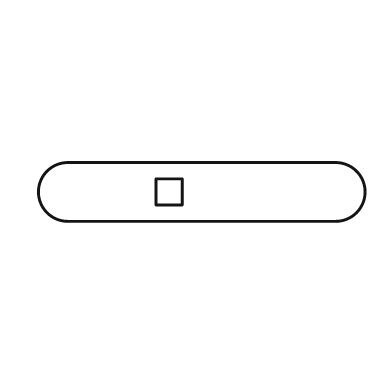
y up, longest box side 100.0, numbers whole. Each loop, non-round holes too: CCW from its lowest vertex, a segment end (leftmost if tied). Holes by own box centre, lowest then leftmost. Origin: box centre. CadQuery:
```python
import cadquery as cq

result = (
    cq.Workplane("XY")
    .moveTo(-41.0, -9.0)
    .lineTo(41.0, -9.0)
    .threePointArc((50.0, 0.0), (41.0, 9.0))
    .lineTo(-41.0, 9.0)
    .threePointArc((-50.0, 0.0), (-41.0, -9.0))
    .close()
    .moveTo(-14.0, -4.0)
    .lineTo(-6.0, -4.0)
    .lineTo(-6.0, 4.0)
    .lineTo(-14.0, 4.0)
    .close()
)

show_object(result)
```